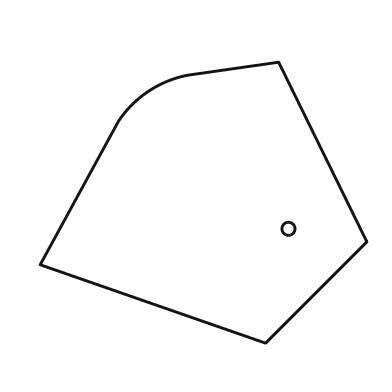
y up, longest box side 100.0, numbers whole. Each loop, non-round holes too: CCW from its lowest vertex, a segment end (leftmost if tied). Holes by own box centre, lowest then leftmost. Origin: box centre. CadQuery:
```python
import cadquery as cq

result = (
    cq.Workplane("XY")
    .moveTo(19.0, -43.0)
    .lineTo(50.0, -12.0)
    .lineTo(23.0, 43.0)
    .lineTo(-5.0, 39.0)
    .threePointArc((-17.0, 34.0), (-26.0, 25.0))
    .lineTo(-50.0, -19.0)
    .close()
    .moveTo(26.0, -8.0)
    .circle(2.0)
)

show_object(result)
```